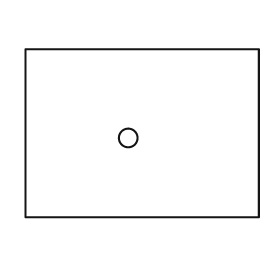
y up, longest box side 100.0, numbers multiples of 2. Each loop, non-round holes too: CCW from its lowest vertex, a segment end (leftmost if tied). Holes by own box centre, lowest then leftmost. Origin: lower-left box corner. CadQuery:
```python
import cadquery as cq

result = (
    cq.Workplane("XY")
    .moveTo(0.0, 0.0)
    .lineTo(100.0, 0.0)
    .lineTo(100.0, 72.0)
    .lineTo(0.0, 72.0)
    .close()
    .moveTo(44.0, 34.0)
    .circle(4.0)
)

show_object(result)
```